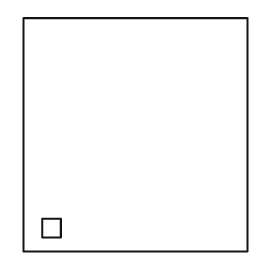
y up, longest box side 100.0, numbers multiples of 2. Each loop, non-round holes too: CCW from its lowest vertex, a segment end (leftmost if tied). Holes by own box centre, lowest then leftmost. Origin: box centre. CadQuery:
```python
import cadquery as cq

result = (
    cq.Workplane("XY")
    .moveTo(-48.0, -50.0)
    .lineTo(48.0, -50.0)
    .lineTo(48.0, 50.0)
    .lineTo(-48.0, 50.0)
    .close()
    .moveTo(-40.0, -44.0)
    .lineTo(-32.0, -44.0)
    .lineTo(-32.0, -36.0)
    .lineTo(-40.0, -36.0)
    .close()
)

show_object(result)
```